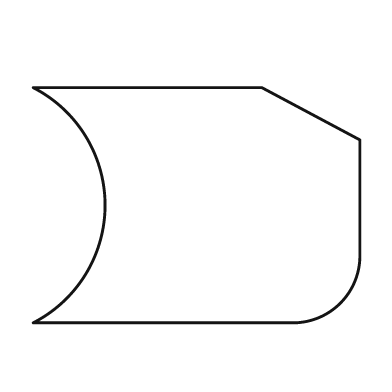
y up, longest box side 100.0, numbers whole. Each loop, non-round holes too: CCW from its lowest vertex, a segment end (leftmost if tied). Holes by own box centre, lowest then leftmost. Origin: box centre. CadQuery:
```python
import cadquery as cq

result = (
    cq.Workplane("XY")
    .moveTo(-50.0, -36.0)
    .lineTo(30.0, -36.0)
    .threePointArc((44.0, -30.0), (50.0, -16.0))
    .lineTo(50.0, 20.0)
    .lineTo(20.0, 36.0)
    .lineTo(-50.0, 36.0)
    .threePointArc((-28.0, 0.0), (-50.0, -36.0))
    .close()
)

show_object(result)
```